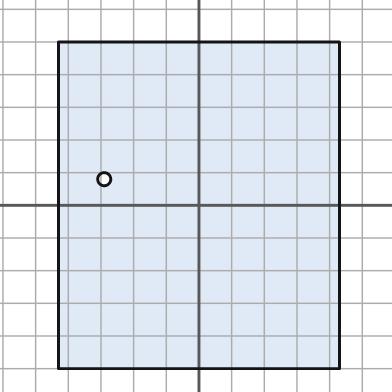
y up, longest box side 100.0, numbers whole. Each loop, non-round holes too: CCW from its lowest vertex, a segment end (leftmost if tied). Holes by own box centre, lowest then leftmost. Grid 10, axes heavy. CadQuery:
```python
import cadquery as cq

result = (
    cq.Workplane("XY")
    .moveTo(-43.0, -50.0)
    .lineTo(43.0, -50.0)
    .lineTo(43.0, 50.0)
    .lineTo(-43.0, 50.0)
    .close()
    .moveTo(-29.0, 8.0)
    .circle(2.0)
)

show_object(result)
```